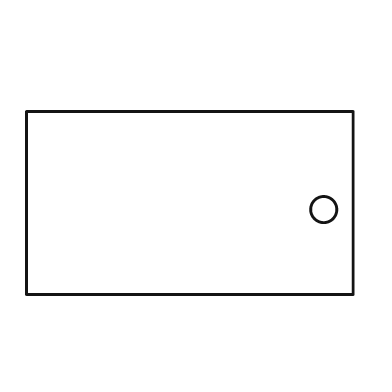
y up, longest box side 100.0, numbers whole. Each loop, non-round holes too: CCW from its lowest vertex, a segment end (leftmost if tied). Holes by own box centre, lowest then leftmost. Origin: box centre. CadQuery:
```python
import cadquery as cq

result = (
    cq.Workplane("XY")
    .moveTo(-50.0, -28.0)
    .lineTo(50.0, -28.0)
    .lineTo(50.0, 28.0)
    .lineTo(-50.0, 28.0)
    .close()
    .moveTo(41.0, -2.0)
    .circle(4.0)
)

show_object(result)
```